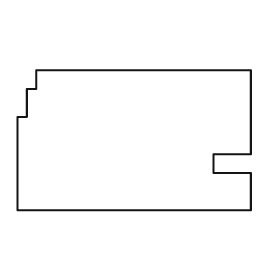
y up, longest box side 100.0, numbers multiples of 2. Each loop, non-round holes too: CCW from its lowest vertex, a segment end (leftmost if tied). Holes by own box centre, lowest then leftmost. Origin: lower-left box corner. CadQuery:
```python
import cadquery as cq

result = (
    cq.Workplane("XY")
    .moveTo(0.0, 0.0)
    .lineTo(100.0, 0.0)
    .lineTo(100.0, 16.0)
    .lineTo(84.0, 16.0)
    .lineTo(84.0, 24.0)
    .lineTo(100.0, 24.0)
    .lineTo(100.0, 60.0)
    .lineTo(8.0, 60.0)
    .lineTo(8.0, 52.0)
    .lineTo(4.0, 52.0)
    .lineTo(4.0, 40.0)
    .lineTo(0.0, 40.0)
    .close()
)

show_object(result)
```